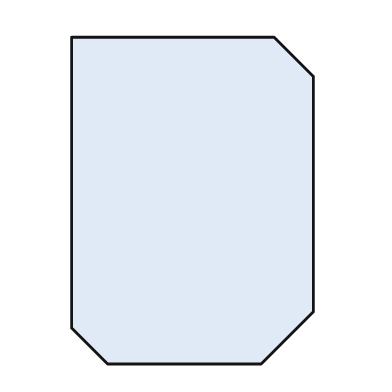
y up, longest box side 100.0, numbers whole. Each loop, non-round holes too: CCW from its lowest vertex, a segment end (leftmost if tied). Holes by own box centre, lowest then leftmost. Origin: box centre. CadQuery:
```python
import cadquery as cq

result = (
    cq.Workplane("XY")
    .moveTo(-26.0, -50.0)
    .lineTo(21.0, -50.0)
    .lineTo(37.0, -34.0)
    .lineTo(37.0, 38.0)
    .lineTo(25.0, 50.0)
    .lineTo(-37.0, 50.0)
    .lineTo(-37.0, -39.0)
    .close()
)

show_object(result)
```